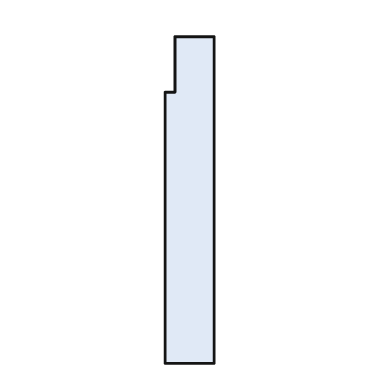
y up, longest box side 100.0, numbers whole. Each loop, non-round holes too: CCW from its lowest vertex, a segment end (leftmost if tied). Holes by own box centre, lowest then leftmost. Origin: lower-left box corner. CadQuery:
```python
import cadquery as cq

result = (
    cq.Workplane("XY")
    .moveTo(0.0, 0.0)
    .lineTo(15.0, 0.0)
    .lineTo(15.0, 100.0)
    .lineTo(3.0, 100.0)
    .lineTo(3.0, 83.0)
    .lineTo(0.0, 83.0)
    .close()
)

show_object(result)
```